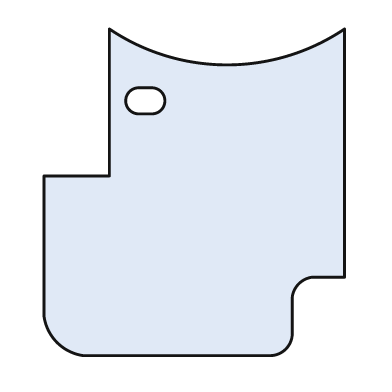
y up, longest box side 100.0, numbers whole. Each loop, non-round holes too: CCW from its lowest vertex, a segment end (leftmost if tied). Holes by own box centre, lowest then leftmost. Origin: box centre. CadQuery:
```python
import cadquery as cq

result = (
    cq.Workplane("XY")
    .moveTo(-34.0, -50.0)
    .lineTo(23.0, -50.0)
    .threePointArc((28.0, -48.0), (30.0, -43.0))
    .lineTo(30.0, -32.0)
    .threePointArc((32.0, -28.0), (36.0, -26.0))
    .lineTo(46.0, -26.0)
    .lineTo(46.0, 50.0)
    .threePointArc((10.0, 39.0), (-26.0, 50.0))
    .lineTo(-26.0, 5.0)
    .lineTo(-46.0, 5.0)
    .lineTo(-46.0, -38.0)
    .threePointArc((-42.0, -46.0), (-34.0, -50.0))
    .close()
    .moveTo(-17.0, 24.0)
    .lineTo(-13.0, 24.0)
    .threePointArc((-9.0, 28.0), (-13.0, 32.0))
    .lineTo(-17.0, 32.0)
    .threePointArc((-21.0, 28.0), (-17.0, 24.0))
    .close()
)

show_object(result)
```